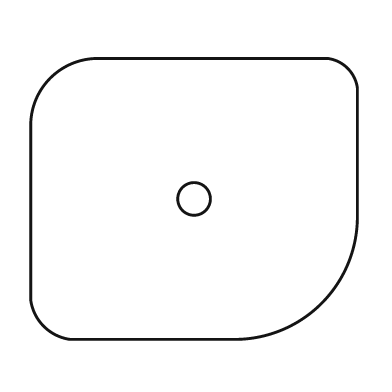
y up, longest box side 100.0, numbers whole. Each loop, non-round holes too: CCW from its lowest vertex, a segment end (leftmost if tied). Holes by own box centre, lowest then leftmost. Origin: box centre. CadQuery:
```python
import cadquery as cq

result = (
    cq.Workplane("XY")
    .moveTo(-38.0, -43.0)
    .lineTo(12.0, -43.0)
    .threePointArc((39.0, -32.0), (50.0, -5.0))
    .lineTo(50.0, 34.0)
    .threePointArc((47.0, 40.0), (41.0, 43.0))
    .lineTo(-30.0, 43.0)
    .threePointArc((-44.0, 37.0), (-50.0, 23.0))
    .lineTo(-50.0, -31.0)
    .threePointArc((-46.0, -39.0), (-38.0, -43.0))
    .close()
    .moveTo(0.0, 0.0)
    .circle(5.0)
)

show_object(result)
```